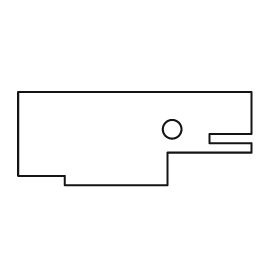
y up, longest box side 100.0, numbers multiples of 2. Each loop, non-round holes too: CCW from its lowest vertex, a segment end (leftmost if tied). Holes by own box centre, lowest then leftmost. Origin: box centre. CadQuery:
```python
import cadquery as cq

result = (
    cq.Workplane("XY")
    .moveTo(-30.0, -20.0)
    .lineTo(14.0, -20.0)
    .lineTo(14.0, -6.0)
    .lineTo(50.0, -6.0)
    .lineTo(50.0, -2.0)
    .lineTo(32.0, -2.0)
    .lineTo(32.0, 2.0)
    .lineTo(50.0, 2.0)
    .lineTo(50.0, 20.0)
    .lineTo(-50.0, 20.0)
    .lineTo(-50.0, -16.0)
    .lineTo(-30.0, -16.0)
    .close()
    .moveTo(16.0, 4.0)
    .circle(4.0)
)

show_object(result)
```